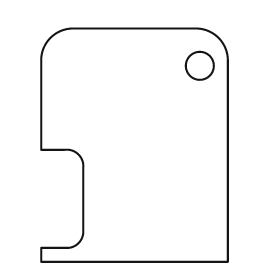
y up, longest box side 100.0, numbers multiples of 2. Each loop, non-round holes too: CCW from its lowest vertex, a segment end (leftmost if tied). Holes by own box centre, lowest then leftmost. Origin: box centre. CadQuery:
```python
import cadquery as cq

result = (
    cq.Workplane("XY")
    .moveTo(-40.0, -50.0)
    .lineTo(40.0, -50.0)
    .lineTo(40.0, 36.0)
    .threePointArc((36.0, 46.0), (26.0, 50.0))
    .lineTo(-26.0, 50.0)
    .threePointArc((-36.0, 46.0), (-40.0, 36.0))
    .lineTo(-40.0, -2.0)
    .lineTo(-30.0, -2.0)
    .threePointArc((-24.0, -4.0), (-22.0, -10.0))
    .lineTo(-22.0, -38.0)
    .threePointArc((-24.0, -42.0), (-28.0, -44.0))
    .lineTo(-40.0, -44.0)
    .close()
    .moveTo(28.0, 34.0)
    .circle(6.0)
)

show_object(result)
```